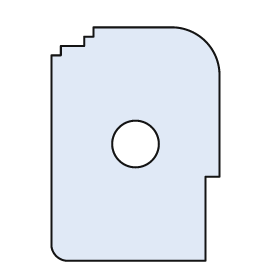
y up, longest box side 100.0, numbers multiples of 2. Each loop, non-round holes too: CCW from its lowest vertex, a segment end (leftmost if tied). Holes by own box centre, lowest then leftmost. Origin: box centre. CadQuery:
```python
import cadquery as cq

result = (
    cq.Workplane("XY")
    .moveTo(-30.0, -50.0)
    .lineTo(30.0, -50.0)
    .lineTo(30.0, -14.0)
    .lineTo(36.0, -14.0)
    .lineTo(36.0, 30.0)
    .threePointArc((30.0, 44.0), (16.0, 50.0))
    .lineTo(-18.0, 50.0)
    .lineTo(-18.0, 46.0)
    .lineTo(-22.0, 46.0)
    .lineTo(-22.0, 42.0)
    .lineTo(-32.0, 42.0)
    .lineTo(-32.0, 38.0)
    .lineTo(-36.0, 38.0)
    .lineTo(-36.0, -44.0)
    .threePointArc((-34.0, -48.0), (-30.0, -50.0))
    .close()
    .moveTo(0.0, 0.0)
    .circle(10.0)
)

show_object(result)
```